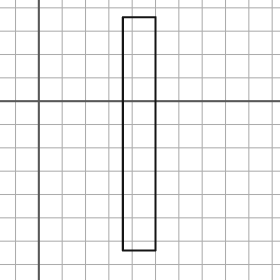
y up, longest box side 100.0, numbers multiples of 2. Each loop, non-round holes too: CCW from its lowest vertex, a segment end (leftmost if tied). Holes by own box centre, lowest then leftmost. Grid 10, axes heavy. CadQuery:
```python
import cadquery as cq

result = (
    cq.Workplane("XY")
    .moveTo(36.0, -64.0)
    .lineTo(50.0, -64.0)
    .lineTo(50.0, 36.0)
    .lineTo(36.0, 36.0)
    .close()
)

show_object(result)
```